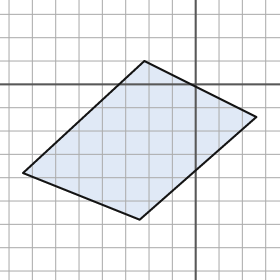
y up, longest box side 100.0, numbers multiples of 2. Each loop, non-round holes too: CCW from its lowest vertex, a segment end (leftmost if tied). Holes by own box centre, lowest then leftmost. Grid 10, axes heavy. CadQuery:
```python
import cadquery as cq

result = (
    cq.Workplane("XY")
    .moveTo(-24.0, -58.0)
    .lineTo(26.0, -14.0)
    .lineTo(-22.0, 10.0)
    .lineTo(-74.0, -38.0)
    .close()
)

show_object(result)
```